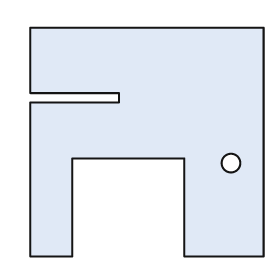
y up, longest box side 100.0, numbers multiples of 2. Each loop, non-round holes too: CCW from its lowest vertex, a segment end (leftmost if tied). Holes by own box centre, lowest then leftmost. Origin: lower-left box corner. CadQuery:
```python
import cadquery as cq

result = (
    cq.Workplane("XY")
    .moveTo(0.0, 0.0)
    .lineTo(18.0, 0.0)
    .lineTo(18.0, 42.0)
    .lineTo(66.0, 42.0)
    .lineTo(66.0, 0.0)
    .lineTo(100.0, 0.0)
    .lineTo(100.0, 98.0)
    .lineTo(0.0, 98.0)
    .lineTo(0.0, 70.0)
    .lineTo(38.0, 70.0)
    .lineTo(38.0, 66.0)
    .lineTo(0.0, 66.0)
    .close()
    .moveTo(86.0, 40.0)
    .circle(4.0)
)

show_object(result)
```